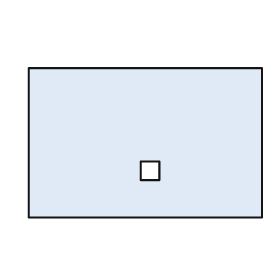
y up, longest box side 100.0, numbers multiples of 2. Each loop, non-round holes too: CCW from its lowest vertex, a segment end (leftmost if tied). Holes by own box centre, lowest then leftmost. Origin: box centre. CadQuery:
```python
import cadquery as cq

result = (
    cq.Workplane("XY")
    .moveTo(-50.0, -32.0)
    .lineTo(50.0, -32.0)
    .lineTo(50.0, 32.0)
    .lineTo(-50.0, 32.0)
    .close()
    .moveTo(-2.0, -16.0)
    .lineTo(6.0, -16.0)
    .lineTo(6.0, -8.0)
    .lineTo(-2.0, -8.0)
    .close()
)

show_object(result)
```